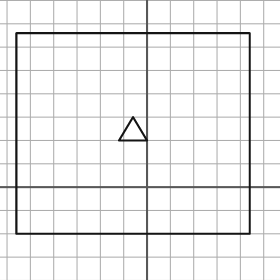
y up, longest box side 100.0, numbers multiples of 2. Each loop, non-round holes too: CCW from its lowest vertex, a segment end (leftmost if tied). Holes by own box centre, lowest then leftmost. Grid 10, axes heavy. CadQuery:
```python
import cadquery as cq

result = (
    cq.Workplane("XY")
    .moveTo(-56.0, -20.0)
    .lineTo(44.0, -20.0)
    .lineTo(44.0, 66.0)
    .lineTo(-56.0, 66.0)
    .close()
    .moveTo(-12.0, 20.0)
    .lineTo(0.0, 20.0)
    .lineTo(-6.0, 30.0)
    .close()
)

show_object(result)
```